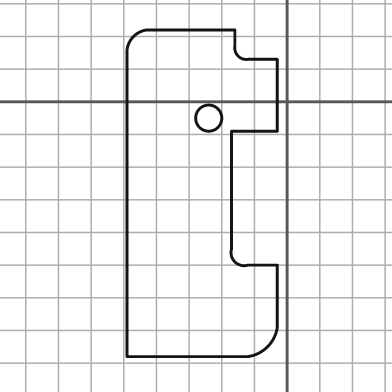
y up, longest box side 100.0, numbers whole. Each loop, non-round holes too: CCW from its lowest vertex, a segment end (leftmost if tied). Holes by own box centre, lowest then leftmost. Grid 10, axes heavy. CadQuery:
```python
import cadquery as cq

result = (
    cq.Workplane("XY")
    .moveTo(-49.0, -78.0)
    .lineTo(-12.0, -78.0)
    .threePointArc((-6.0, -75.0), (-3.0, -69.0))
    .lineTo(-3.0, -50.0)
    .lineTo(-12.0, -50.0)
    .threePointArc((-16.0, -49.0), (-17.0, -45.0))
    .lineTo(-17.0, -9.0)
    .lineTo(-3.0, -9.0)
    .lineTo(-3.0, 13.0)
    .lineTo(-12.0, 13.0)
    .threePointArc((-15.0, 14.0), (-16.0, 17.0))
    .lineTo(-16.0, 22.0)
    .lineTo(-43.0, 22.0)
    .threePointArc((-47.0, 20.0), (-49.0, 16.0))
    .close()
    .moveTo(-24.0, -5.0)
    .circle(4.0)
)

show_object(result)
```